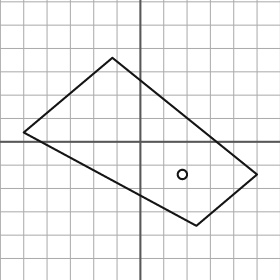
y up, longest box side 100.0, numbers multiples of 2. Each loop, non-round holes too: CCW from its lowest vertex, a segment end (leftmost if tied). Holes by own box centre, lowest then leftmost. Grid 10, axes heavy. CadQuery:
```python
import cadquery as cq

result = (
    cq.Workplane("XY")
    .moveTo(24.0, -36.0)
    .lineTo(50.0, -14.0)
    .lineTo(-12.0, 36.0)
    .lineTo(-50.0, 4.0)
    .close()
    .moveTo(18.0, -14.0)
    .circle(2.0)
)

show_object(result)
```